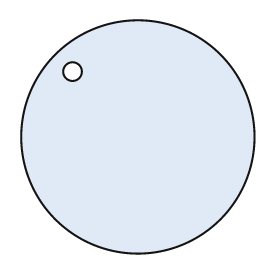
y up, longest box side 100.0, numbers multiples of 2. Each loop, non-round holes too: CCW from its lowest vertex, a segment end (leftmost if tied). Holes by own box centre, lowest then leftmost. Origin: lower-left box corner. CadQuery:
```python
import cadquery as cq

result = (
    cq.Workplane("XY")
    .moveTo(50.0, 50.0)
    .circle(50.0)
    .moveTo(22.0, 78.0)
    .circle(4.0)
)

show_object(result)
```